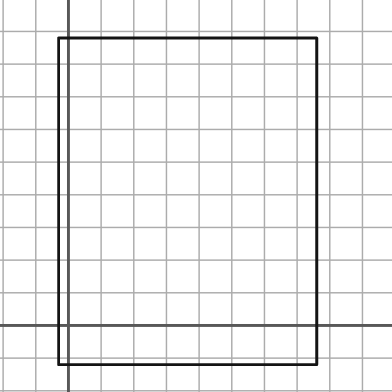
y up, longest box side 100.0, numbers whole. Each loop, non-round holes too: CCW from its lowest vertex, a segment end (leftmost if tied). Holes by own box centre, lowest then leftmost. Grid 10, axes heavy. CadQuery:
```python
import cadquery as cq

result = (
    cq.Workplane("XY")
    .moveTo(-3.0, -12.0)
    .lineTo(76.0, -12.0)
    .lineTo(76.0, 88.0)
    .lineTo(-3.0, 88.0)
    .close()
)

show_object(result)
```